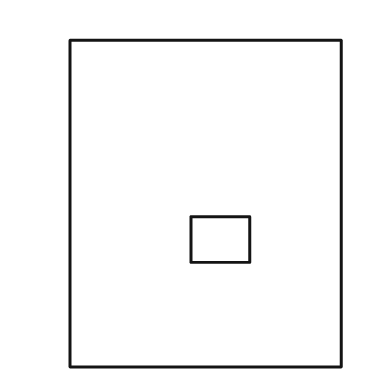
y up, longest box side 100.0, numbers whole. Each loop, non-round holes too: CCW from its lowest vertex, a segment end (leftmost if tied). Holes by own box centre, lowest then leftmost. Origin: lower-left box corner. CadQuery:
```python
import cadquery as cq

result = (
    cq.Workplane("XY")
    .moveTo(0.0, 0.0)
    .lineTo(83.0, 0.0)
    .lineTo(83.0, 100.0)
    .lineTo(0.0, 100.0)
    .close()
    .moveTo(37.0, 32.0)
    .lineTo(55.0, 32.0)
    .lineTo(55.0, 46.0)
    .lineTo(37.0, 46.0)
    .close()
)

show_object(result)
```